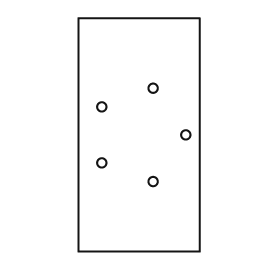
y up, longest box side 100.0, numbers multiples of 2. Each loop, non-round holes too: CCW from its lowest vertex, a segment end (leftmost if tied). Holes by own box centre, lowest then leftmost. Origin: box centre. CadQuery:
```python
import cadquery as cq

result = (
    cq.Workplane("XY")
    .moveTo(-26.0, -50.0)
    .lineTo(26.0, -50.0)
    .lineTo(26.0, 50.0)
    .lineTo(-26.0, 50.0)
    .close()
    .moveTo(6.0, -20.0)
    .circle(2.0)
    .moveTo(-16.0, -12.0)
    .circle(2.0)
    .moveTo(20.0, 0.0)
    .circle(2.0)
    .moveTo(-16.0, 12.0)
    .circle(2.0)
    .moveTo(6.0, 20.0)
    .circle(2.0)
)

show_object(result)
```